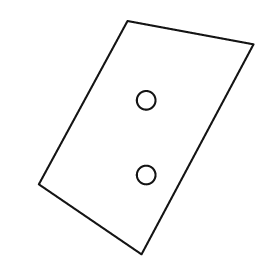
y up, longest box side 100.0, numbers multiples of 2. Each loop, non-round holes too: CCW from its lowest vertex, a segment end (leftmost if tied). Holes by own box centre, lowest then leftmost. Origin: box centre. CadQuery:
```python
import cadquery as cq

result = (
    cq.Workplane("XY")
    .moveTo(-2.0, -50.0)
    .lineTo(46.0, 40.0)
    .lineTo(-8.0, 50.0)
    .lineTo(-46.0, -20.0)
    .close()
    .moveTo(0.0, -16.0)
    .circle(4.0)
    .moveTo(0.0, 16.0)
    .circle(4.0)
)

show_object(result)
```